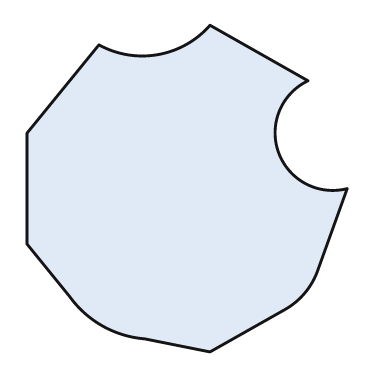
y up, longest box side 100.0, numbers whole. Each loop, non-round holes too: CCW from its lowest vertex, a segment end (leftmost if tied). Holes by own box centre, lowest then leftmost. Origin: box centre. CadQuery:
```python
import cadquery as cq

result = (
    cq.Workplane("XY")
    .moveTo(7.0, -50.0)
    .lineTo(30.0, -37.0)
    .threePointArc((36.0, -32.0), (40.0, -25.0))
    .lineTo(49.0, 0.0)
    .threePointArc((28.0, 11.0), (37.0, 33.0))
    .lineTo(7.0, 50.0)
    .threePointArc((-9.0, 41.0), (-27.0, 44.0))
    .lineTo(-49.0, 17.0)
    .lineTo(-49.0, -17.0)
    .lineTo(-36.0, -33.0)
    .threePointArc((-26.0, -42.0), (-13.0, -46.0))
    .close()
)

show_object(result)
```